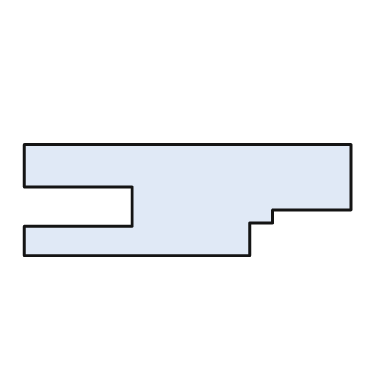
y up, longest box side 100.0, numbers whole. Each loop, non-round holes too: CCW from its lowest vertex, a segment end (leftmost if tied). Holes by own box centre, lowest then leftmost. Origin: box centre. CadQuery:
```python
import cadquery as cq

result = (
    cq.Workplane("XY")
    .moveTo(-50.0, -17.0)
    .lineTo(19.0, -17.0)
    .lineTo(19.0, -7.0)
    .lineTo(26.0, -7.0)
    .lineTo(26.0, -3.0)
    .lineTo(50.0, -3.0)
    .lineTo(50.0, 17.0)
    .lineTo(-50.0, 17.0)
    .lineTo(-50.0, 4.0)
    .lineTo(-17.0, 4.0)
    .lineTo(-17.0, -8.0)
    .lineTo(-50.0, -8.0)
    .close()
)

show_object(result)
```